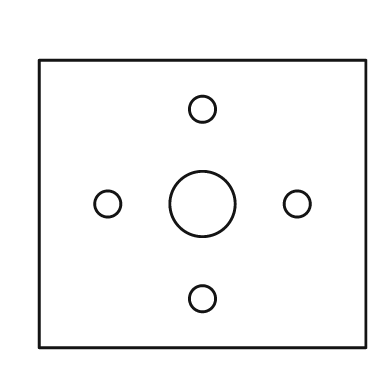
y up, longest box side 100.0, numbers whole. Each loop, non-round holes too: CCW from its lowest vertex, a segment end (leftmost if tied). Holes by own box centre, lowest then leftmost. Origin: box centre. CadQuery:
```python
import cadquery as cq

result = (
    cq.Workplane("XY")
    .moveTo(-50.0, -44.0)
    .lineTo(50.0, -44.0)
    .lineTo(50.0, 44.0)
    .lineTo(-50.0, 44.0)
    .close()
    .moveTo(0.0, -29.0)
    .circle(4.0)
    .moveTo(-29.0, 0.0)
    .circle(4.0)
    .moveTo(0.0, 0.0)
    .circle(10.0)
    .moveTo(29.0, 0.0)
    .circle(4.0)
    .moveTo(0.0, 29.0)
    .circle(4.0)
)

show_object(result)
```